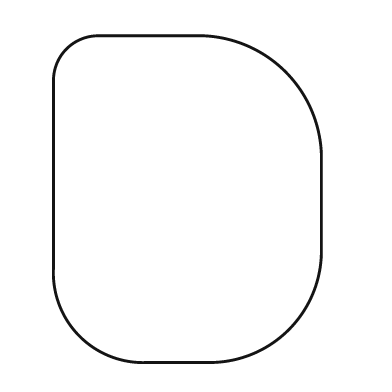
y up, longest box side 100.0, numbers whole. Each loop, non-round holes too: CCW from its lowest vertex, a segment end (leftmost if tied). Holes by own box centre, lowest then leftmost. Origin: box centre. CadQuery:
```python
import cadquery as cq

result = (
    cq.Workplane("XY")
    .moveTo(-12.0, -50.0)
    .lineTo(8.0, -50.0)
    .threePointArc((31.0, -40.0), (41.0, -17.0))
    .lineTo(41.0, 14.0)
    .threePointArc((30.0, 39.0), (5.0, 50.0))
    .lineTo(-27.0, 50.0)
    .threePointArc((-37.0, 46.0), (-41.0, 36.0))
    .lineTo(-41.0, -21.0)
    .threePointArc((-33.0, -42.0), (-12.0, -50.0))
    .close()
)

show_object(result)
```